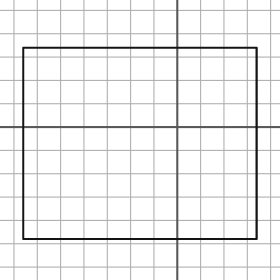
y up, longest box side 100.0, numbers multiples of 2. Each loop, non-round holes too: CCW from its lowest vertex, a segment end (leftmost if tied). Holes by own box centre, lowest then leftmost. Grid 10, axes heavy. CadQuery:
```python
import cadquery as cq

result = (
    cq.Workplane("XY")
    .moveTo(-66.0, -48.0)
    .lineTo(34.0, -48.0)
    .lineTo(34.0, 34.0)
    .lineTo(-66.0, 34.0)
    .close()
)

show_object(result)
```